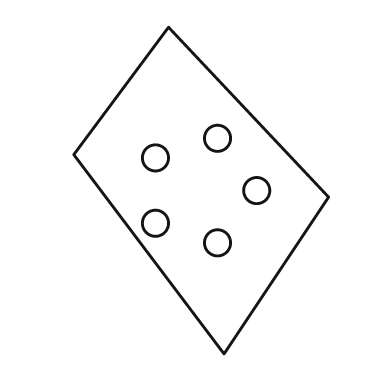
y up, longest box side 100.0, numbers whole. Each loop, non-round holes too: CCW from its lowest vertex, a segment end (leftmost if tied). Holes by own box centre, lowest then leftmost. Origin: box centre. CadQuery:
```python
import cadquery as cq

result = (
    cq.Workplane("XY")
    .moveTo(7.0, -50.0)
    .lineTo(39.0, -2.0)
    .lineTo(-10.0, 50.0)
    .lineTo(-39.0, 11.0)
    .close()
    .moveTo(5.0, -16.0)
    .circle(4.0)
    .moveTo(-14.0, -10.0)
    .circle(4.0)
    .moveTo(17.0, 0.0)
    .circle(4.0)
    .moveTo(-14.0, 10.0)
    .circle(4.0)
    .moveTo(5.0, 16.0)
    .circle(4.0)
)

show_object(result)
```